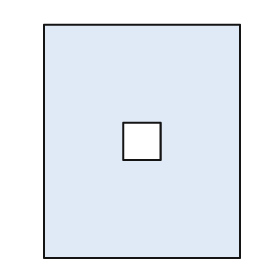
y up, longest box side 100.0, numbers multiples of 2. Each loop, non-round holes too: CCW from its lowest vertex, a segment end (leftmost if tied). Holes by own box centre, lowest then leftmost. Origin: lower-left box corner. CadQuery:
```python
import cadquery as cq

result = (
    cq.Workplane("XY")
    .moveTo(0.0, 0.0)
    .lineTo(84.0, 0.0)
    .lineTo(84.0, 100.0)
    .lineTo(0.0, 100.0)
    .close()
    .moveTo(34.0, 42.0)
    .lineTo(50.0, 42.0)
    .lineTo(50.0, 58.0)
    .lineTo(34.0, 58.0)
    .close()
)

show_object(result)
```